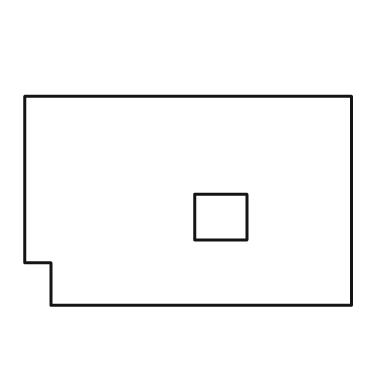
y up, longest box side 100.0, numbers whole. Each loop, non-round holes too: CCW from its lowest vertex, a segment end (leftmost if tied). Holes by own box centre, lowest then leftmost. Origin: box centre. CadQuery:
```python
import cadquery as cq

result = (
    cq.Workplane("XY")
    .moveTo(-42.0, -32.0)
    .lineTo(50.0, -32.0)
    .lineTo(50.0, 32.0)
    .lineTo(-50.0, 32.0)
    .lineTo(-50.0, -19.0)
    .lineTo(-42.0, -19.0)
    .close()
    .moveTo(2.0, -12.0)
    .lineTo(18.0, -12.0)
    .lineTo(18.0, 2.0)
    .lineTo(2.0, 2.0)
    .close()
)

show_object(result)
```